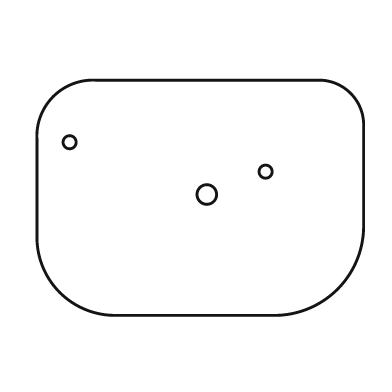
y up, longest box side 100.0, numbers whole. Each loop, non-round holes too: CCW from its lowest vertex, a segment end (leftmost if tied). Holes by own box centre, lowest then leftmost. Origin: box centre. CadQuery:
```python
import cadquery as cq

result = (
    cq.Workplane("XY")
    .moveTo(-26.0, -36.0)
    .lineTo(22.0, -36.0)
    .threePointArc((42.0, -28.0), (50.0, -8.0))
    .lineTo(50.0, 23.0)
    .threePointArc((46.0, 32.0), (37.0, 36.0))
    .lineTo(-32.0, 36.0)
    .threePointArc((-45.0, 31.0), (-50.0, 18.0))
    .lineTo(-50.0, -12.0)
    .threePointArc((-43.0, -29.0), (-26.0, -36.0))
    .close()
    .moveTo(2.0, 1.0)
    .circle(3.0)
    .moveTo(20.0, 8.0)
    .circle(2.0)
    .moveTo(-40.0, 17.0)
    .circle(2.0)
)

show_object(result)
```